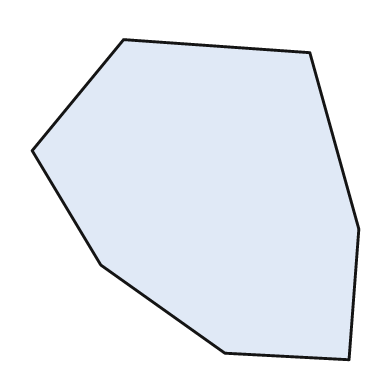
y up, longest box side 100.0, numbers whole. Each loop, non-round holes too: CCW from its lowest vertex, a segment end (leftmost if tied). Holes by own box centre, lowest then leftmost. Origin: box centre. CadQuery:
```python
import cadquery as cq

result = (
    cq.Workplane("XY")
    .moveTo(47.0, -49.0)
    .lineTo(50.0, -9.0)
    .lineTo(35.0, 45.0)
    .lineTo(-22.0, 49.0)
    .lineTo(-50.0, 15.0)
    .lineTo(-29.0, -20.0)
    .lineTo(9.0, -47.0)
    .close()
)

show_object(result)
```